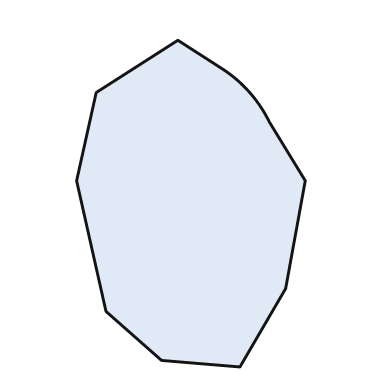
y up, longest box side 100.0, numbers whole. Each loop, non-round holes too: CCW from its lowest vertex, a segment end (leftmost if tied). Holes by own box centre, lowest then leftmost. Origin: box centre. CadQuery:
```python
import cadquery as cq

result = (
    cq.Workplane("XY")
    .moveTo(15.0, -50.0)
    .lineTo(29.0, -26.0)
    .lineTo(35.0, 7.0)
    .lineTo(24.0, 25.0)
    .threePointArc((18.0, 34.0), (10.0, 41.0))
    .lineTo(-4.0, 50.0)
    .lineTo(-29.0, 34.0)
    .lineTo(-35.0, 7.0)
    .lineTo(-26.0, -33.0)
    .lineTo(-9.0, -48.0)
    .close()
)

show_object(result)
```